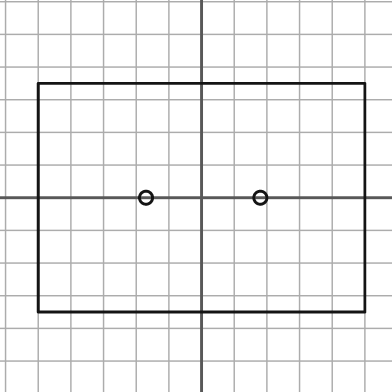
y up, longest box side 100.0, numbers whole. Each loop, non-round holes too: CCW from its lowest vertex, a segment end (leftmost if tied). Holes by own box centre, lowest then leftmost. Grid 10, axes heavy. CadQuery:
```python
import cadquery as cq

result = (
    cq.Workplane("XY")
    .moveTo(-50.0, -35.0)
    .lineTo(50.0, -35.0)
    .lineTo(50.0, 35.0)
    .lineTo(-50.0, 35.0)
    .close()
    .moveTo(-17.0, 0.0)
    .circle(2.0)
    .moveTo(18.0, 0.0)
    .circle(2.0)
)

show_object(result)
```